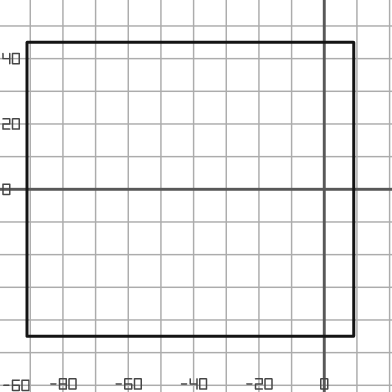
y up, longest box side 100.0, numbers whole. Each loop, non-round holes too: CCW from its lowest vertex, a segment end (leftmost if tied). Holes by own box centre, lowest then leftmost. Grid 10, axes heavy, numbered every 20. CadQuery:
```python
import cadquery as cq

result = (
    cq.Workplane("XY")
    .moveTo(-91.0, -45.0)
    .lineTo(9.0, -45.0)
    .lineTo(9.0, 45.0)
    .lineTo(-91.0, 45.0)
    .close()
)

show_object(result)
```